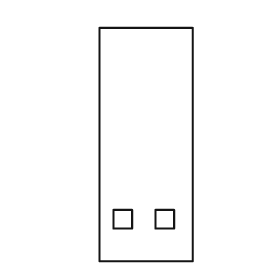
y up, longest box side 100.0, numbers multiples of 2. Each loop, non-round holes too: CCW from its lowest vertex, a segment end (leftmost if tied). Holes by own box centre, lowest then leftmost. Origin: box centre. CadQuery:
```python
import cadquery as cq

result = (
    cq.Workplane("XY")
    .moveTo(-20.0, -50.0)
    .lineTo(20.0, -50.0)
    .lineTo(20.0, 50.0)
    .lineTo(-20.0, 50.0)
    .close()
    .moveTo(-14.0, -36.0)
    .lineTo(-6.0, -36.0)
    .lineTo(-6.0, -28.0)
    .lineTo(-14.0, -28.0)
    .close()
    .moveTo(4.0, -36.0)
    .lineTo(12.0, -36.0)
    .lineTo(12.0, -28.0)
    .lineTo(4.0, -28.0)
    .close()
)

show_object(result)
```